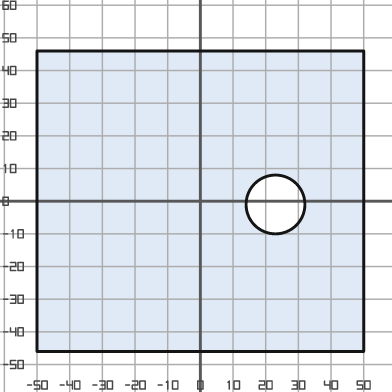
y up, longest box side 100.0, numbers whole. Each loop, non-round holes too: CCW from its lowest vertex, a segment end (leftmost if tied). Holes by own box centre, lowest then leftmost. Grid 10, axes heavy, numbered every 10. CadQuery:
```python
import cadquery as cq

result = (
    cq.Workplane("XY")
    .moveTo(-50.0, -46.0)
    .lineTo(50.0, -46.0)
    .lineTo(50.0, 46.0)
    .lineTo(-50.0, 46.0)
    .close()
    .moveTo(23.0, -1.0)
    .circle(9.0)
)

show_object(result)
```